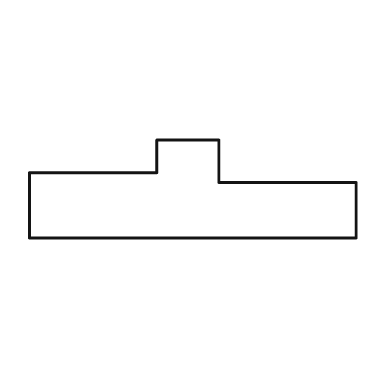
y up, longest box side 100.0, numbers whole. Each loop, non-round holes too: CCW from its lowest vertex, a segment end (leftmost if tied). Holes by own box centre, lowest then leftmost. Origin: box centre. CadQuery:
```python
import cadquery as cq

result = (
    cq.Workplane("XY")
    .moveTo(-50.0, -15.0)
    .lineTo(50.0, -15.0)
    .lineTo(50.0, 2.0)
    .lineTo(8.0, 2.0)
    .lineTo(8.0, 15.0)
    .lineTo(-11.0, 15.0)
    .lineTo(-11.0, 5.0)
    .lineTo(-50.0, 5.0)
    .close()
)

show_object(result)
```